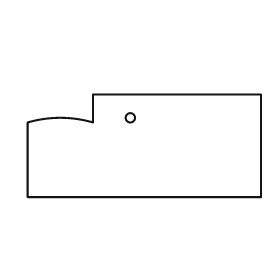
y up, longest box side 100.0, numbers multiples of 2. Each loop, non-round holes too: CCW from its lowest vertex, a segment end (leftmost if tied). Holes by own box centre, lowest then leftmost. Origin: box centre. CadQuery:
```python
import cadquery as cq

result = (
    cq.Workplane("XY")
    .moveTo(-50.0, -22.0)
    .lineTo(50.0, -22.0)
    .lineTo(50.0, 22.0)
    .lineTo(-22.0, 22.0)
    .lineTo(-22.0, 10.0)
    .threePointArc((-36.0, 12.0), (-50.0, 10.0))
    .close()
    .moveTo(-6.0, 12.0)
    .circle(2.0)
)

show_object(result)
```